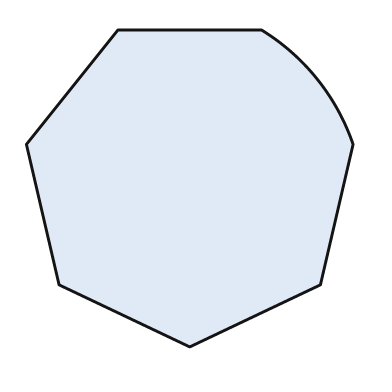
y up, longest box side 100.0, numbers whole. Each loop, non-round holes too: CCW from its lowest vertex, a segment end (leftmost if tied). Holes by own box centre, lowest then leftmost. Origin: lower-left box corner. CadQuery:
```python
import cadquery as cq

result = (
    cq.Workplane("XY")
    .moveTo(50.0, 0.0)
    .lineTo(90.0, 19.0)
    .lineTo(100.0, 62.0)
    .threePointArc((89.0, 82.0), (72.0, 97.0))
    .lineTo(28.0, 97.0)
    .lineTo(0.0, 62.0)
    .lineTo(10.0, 19.0)
    .close()
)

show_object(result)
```